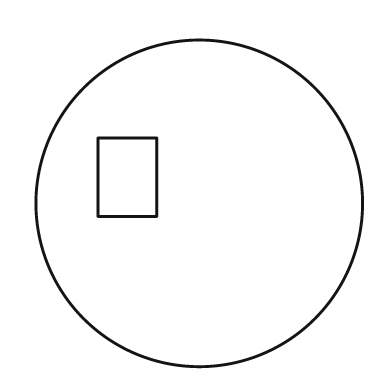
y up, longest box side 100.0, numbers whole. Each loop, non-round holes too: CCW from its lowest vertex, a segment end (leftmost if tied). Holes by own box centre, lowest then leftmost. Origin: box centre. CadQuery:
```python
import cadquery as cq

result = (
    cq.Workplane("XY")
    .moveTo(0.0, 0.0)
    .circle(50.0)
    .moveTo(-31.0, -4.0)
    .lineTo(-13.0, -4.0)
    .lineTo(-13.0, 20.0)
    .lineTo(-31.0, 20.0)
    .close()
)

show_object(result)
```